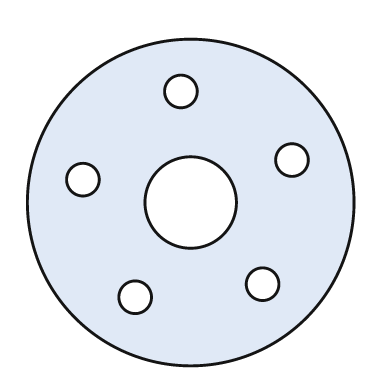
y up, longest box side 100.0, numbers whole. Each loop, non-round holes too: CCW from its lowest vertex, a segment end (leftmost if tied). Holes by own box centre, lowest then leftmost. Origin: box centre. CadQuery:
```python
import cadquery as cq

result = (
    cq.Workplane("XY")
    .moveTo(0.0, 0.0)
    .circle(50.0)
    .moveTo(-17.0, -29.0)
    .circle(5.0)
    .moveTo(22.0, -25.0)
    .circle(5.0)
    .moveTo(0.0, 0.0)
    .circle(14.0)
    .moveTo(-33.0, 7.0)
    .circle(5.0)
    .moveTo(31.0, 13.0)
    .circle(5.0)
    .moveTo(-3.0, 34.0)
    .circle(5.0)
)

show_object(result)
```